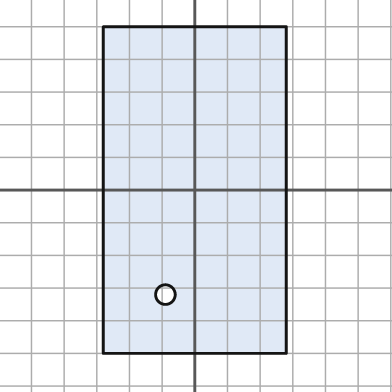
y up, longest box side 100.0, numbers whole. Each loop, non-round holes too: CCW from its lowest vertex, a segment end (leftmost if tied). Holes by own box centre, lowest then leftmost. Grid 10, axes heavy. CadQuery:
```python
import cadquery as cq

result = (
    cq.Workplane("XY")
    .moveTo(-28.0, -50.0)
    .lineTo(28.0, -50.0)
    .lineTo(28.0, 50.0)
    .lineTo(-28.0, 50.0)
    .close()
    .moveTo(-9.0, -32.0)
    .circle(3.0)
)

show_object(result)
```